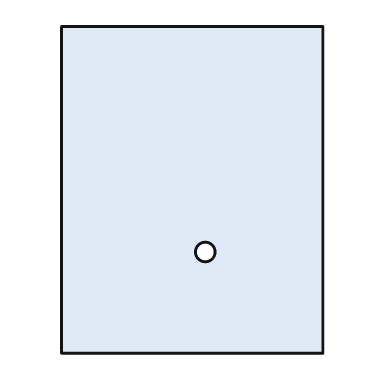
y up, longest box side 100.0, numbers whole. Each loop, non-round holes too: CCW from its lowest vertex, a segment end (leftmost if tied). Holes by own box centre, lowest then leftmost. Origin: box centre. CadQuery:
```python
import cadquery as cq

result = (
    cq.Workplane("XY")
    .moveTo(-40.0, -50.0)
    .lineTo(40.0, -50.0)
    .lineTo(40.0, 50.0)
    .lineTo(-40.0, 50.0)
    .close()
    .moveTo(4.0, -19.0)
    .circle(3.0)
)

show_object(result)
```